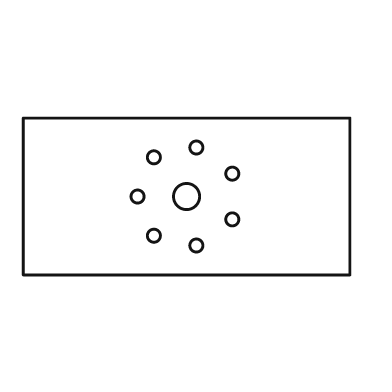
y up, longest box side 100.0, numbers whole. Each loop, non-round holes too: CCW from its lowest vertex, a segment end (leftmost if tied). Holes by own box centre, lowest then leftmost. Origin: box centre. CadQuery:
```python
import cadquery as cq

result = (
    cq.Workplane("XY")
    .moveTo(-50.0, -24.0)
    .lineTo(50.0, -24.0)
    .lineTo(50.0, 24.0)
    .lineTo(-50.0, 24.0)
    .close()
    .moveTo(3.0, -15.0)
    .circle(2.0)
    .moveTo(-10.0, -12.0)
    .circle(2.0)
    .moveTo(14.0, -7.0)
    .circle(2.0)
    .moveTo(-15.0, 0.0)
    .circle(2.0)
    .moveTo(0.0, 0.0)
    .circle(4.0)
    .moveTo(14.0, 7.0)
    .circle(2.0)
    .moveTo(-10.0, 12.0)
    .circle(2.0)
    .moveTo(3.0, 15.0)
    .circle(2.0)
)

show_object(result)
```